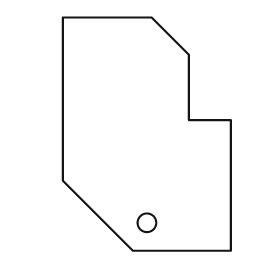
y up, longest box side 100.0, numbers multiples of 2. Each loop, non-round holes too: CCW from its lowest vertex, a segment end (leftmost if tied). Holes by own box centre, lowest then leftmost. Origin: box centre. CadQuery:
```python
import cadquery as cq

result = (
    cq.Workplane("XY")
    .moveTo(-6.0, -50.0)
    .lineTo(36.0, -50.0)
    .lineTo(36.0, 6.0)
    .lineTo(18.0, 6.0)
    .lineTo(18.0, 34.0)
    .lineTo(2.0, 50.0)
    .lineTo(-36.0, 50.0)
    .lineTo(-36.0, -20.0)
    .close()
    .moveTo(0.0, -38.0)
    .circle(4.0)
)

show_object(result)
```